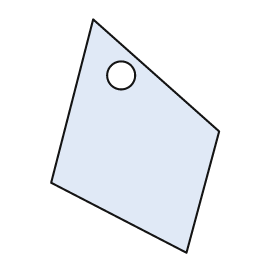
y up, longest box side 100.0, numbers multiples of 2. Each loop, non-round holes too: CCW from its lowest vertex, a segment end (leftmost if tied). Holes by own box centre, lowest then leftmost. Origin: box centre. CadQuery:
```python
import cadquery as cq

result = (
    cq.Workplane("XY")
    .moveTo(22.0, -50.0)
    .lineTo(36.0, 2.0)
    .lineTo(-18.0, 50.0)
    .lineTo(-36.0, -20.0)
    .close()
    .moveTo(-6.0, 26.0)
    .circle(6.0)
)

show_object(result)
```